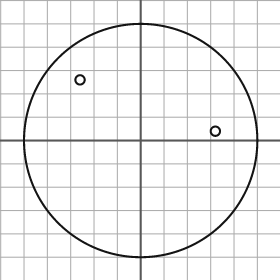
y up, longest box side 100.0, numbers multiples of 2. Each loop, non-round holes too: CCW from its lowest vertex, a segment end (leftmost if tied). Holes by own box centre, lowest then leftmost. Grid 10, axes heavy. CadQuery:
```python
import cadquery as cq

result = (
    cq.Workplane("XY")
    .moveTo(0.0, 0.0)
    .circle(50.0)
    .moveTo(32.0, 4.0)
    .circle(2.0)
    .moveTo(-26.0, 26.0)
    .circle(2.0)
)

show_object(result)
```